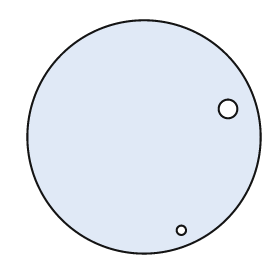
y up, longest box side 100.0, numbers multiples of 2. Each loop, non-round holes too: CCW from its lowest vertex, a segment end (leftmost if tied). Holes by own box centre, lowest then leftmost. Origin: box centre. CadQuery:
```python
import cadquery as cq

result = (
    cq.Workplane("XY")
    .moveTo(0.0, 0.0)
    .circle(50.0)
    .moveTo(16.0, -40.0)
    .circle(2.0)
    .moveTo(36.0, 12.0)
    .circle(4.0)
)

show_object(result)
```